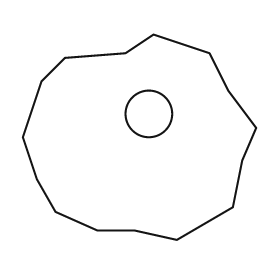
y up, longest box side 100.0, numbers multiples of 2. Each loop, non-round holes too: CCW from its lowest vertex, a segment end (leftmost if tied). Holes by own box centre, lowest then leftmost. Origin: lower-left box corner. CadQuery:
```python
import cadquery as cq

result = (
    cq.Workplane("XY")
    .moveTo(66.0, 0.0)
    .lineTo(90.0, 14.0)
    .lineTo(94.0, 34.0)
    .lineTo(100.0, 48.0)
    .lineTo(88.0, 64.0)
    .lineTo(80.0, 80.0)
    .lineTo(56.0, 88.0)
    .lineTo(44.0, 80.0)
    .lineTo(18.0, 78.0)
    .lineTo(8.0, 68.0)
    .lineTo(0.0, 44.0)
    .lineTo(6.0, 26.0)
    .lineTo(14.0, 12.0)
    .lineTo(32.0, 4.0)
    .lineTo(48.0, 4.0)
    .close()
    .moveTo(54.0, 54.0)
    .circle(10.0)
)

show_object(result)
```